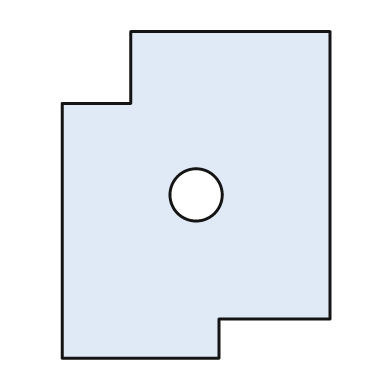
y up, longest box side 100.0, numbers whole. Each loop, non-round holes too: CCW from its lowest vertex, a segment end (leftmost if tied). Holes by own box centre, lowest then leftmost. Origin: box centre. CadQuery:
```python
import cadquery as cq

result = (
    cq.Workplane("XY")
    .moveTo(-41.0, -50.0)
    .lineTo(7.0, -50.0)
    .lineTo(7.0, -38.0)
    .lineTo(41.0, -38.0)
    .lineTo(41.0, 50.0)
    .lineTo(-20.0, 50.0)
    .lineTo(-20.0, 28.0)
    .lineTo(-41.0, 28.0)
    .close()
    .moveTo(0.0, 0.0)
    .circle(8.0)
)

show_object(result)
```